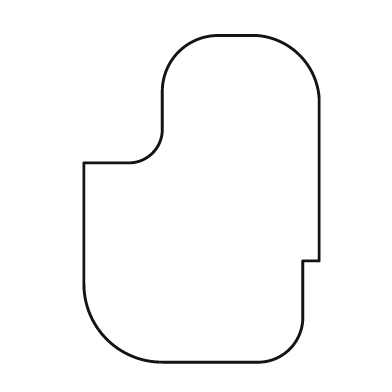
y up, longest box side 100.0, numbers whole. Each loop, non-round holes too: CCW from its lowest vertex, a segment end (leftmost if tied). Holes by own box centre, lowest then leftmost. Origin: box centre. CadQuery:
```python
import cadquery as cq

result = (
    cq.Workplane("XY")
    .moveTo(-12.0, -50.0)
    .lineTo(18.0, -50.0)
    .threePointArc((27.0, -46.0), (31.0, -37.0))
    .lineTo(31.0, -19.0)
    .lineTo(36.0, -19.0)
    .lineTo(36.0, 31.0)
    .threePointArc((30.0, 44.0), (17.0, 50.0))
    .lineTo(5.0, 50.0)
    .threePointArc((-7.0, 45.0), (-12.0, 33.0))
    .lineTo(-12.0, 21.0)
    .threePointArc((-15.0, 14.0), (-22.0, 11.0))
    .lineTo(-36.0, 11.0)
    .lineTo(-36.0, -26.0)
    .threePointArc((-29.0, -43.0), (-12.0, -50.0))
    .close()
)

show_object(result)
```